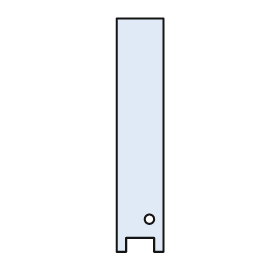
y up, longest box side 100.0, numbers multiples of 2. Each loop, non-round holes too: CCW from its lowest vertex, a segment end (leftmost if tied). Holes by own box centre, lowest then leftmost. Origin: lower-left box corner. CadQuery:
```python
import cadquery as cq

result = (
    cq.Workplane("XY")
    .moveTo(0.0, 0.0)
    .lineTo(4.0, 0.0)
    .lineTo(4.0, 6.0)
    .lineTo(16.0, 6.0)
    .lineTo(16.0, 0.0)
    .lineTo(20.0, 0.0)
    .lineTo(20.0, 100.0)
    .lineTo(0.0, 100.0)
    .close()
    .moveTo(14.0, 14.0)
    .circle(2.0)
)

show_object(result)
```